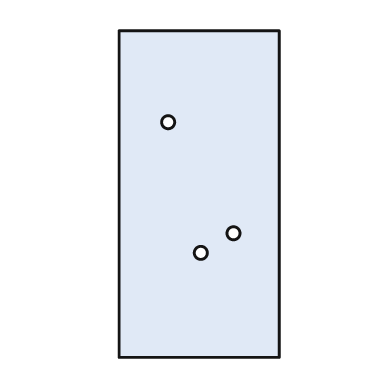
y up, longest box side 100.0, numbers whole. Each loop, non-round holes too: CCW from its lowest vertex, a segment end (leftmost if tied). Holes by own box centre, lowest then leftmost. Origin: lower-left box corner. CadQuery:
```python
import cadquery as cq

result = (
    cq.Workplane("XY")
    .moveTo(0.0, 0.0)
    .lineTo(49.0, 0.0)
    .lineTo(49.0, 100.0)
    .lineTo(0.0, 100.0)
    .close()
    .moveTo(25.0, 32.0)
    .circle(2.0)
    .moveTo(35.0, 38.0)
    .circle(2.0)
    .moveTo(15.0, 72.0)
    .circle(2.0)
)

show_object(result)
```